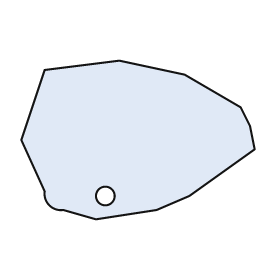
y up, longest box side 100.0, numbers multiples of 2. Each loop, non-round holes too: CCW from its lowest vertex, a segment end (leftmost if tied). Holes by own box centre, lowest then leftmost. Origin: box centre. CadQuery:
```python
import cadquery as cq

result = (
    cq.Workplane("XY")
    .moveTo(-18.0, -34.0)
    .lineTo(8.0, -30.0)
    .lineTo(22.0, -24.0)
    .lineTo(50.0, -4.0)
    .lineTo(48.0, 6.0)
    .lineTo(44.0, 14.0)
    .lineTo(20.0, 28.0)
    .lineTo(-8.0, 34.0)
    .lineTo(-40.0, 30.0)
    .lineTo(-50.0, 0.0)
    .lineTo(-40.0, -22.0)
    .threePointArc((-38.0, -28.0), (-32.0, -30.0))
    .close()
    .moveTo(-14.0, -24.0)
    .circle(4.0)
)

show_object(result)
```